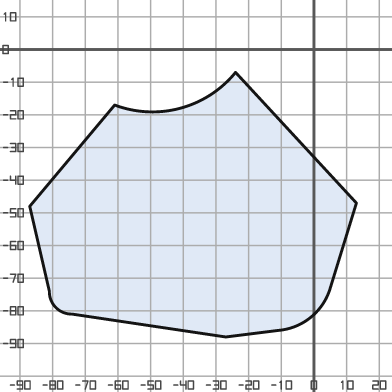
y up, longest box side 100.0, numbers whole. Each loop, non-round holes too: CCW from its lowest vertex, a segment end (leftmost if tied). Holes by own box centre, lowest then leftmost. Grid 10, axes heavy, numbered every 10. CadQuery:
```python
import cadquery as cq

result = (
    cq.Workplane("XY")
    .moveTo(-27.0, -88.0)
    .lineTo(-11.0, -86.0)
    .threePointArc((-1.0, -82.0), (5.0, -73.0))
    .lineTo(13.0, -47.0)
    .lineTo(-24.0, -7.0)
    .threePointArc((-41.0, -18.0), (-61.0, -17.0))
    .lineTo(-87.0, -48.0)
    .lineTo(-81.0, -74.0)
    .threePointArc((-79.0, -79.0), (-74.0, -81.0))
    .close()
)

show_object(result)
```